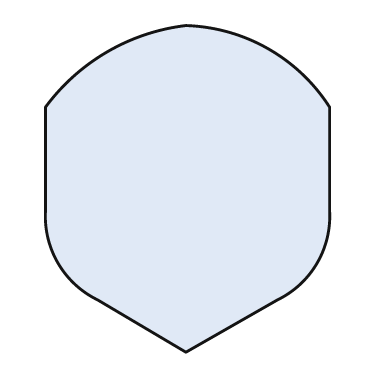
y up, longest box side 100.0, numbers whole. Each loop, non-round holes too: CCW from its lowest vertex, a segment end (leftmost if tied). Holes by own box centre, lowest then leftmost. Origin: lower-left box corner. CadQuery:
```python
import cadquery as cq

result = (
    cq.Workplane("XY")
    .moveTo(43.0, 0.0)
    .lineTo(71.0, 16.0)
    .threePointArc((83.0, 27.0), (87.0, 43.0))
    .lineTo(87.0, 75.0)
    .threePointArc((68.0, 93.0), (43.0, 100.0))
    .threePointArc((19.0, 92.0), (0.0, 75.0))
    .lineTo(0.0, 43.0)
    .threePointArc((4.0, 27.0), (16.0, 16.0))
    .close()
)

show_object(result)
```